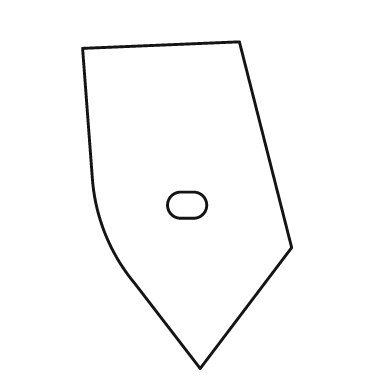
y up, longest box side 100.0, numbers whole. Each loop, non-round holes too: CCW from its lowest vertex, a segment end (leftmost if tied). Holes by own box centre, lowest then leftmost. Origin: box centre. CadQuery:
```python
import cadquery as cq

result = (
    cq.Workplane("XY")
    .moveTo(4.0, -50.0)
    .lineTo(32.0, -13.0)
    .lineTo(16.0, 50.0)
    .lineTo(-32.0, 48.0)
    .lineTo(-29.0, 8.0)
    .threePointArc((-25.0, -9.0), (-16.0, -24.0))
    .close()
    .moveTo(-2.0, -4.0)
    .lineTo(2.0, -4.0)
    .threePointArc((6.0, 0.0), (2.0, 4.0))
    .lineTo(-2.0, 4.0)
    .threePointArc((-6.0, 0.0), (-2.0, -4.0))
    .close()
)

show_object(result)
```